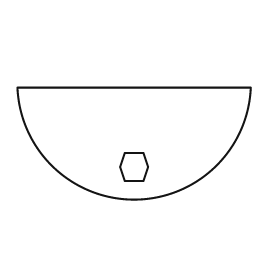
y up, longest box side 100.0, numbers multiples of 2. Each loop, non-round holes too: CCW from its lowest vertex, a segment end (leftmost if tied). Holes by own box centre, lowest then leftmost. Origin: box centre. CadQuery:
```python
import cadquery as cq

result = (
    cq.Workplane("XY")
    .moveTo(-50.0, 24.0)
    .threePointArc((0.0, -24.0), (50.0, 24.0))
    .close()
    .moveTo(-4.0, -16.0)
    .lineTo(4.0, -16.0)
    .lineTo(6.0, -10.0)
    .lineTo(4.0, -4.0)
    .lineTo(-4.0, -4.0)
    .lineTo(-6.0, -10.0)
    .close()
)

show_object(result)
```